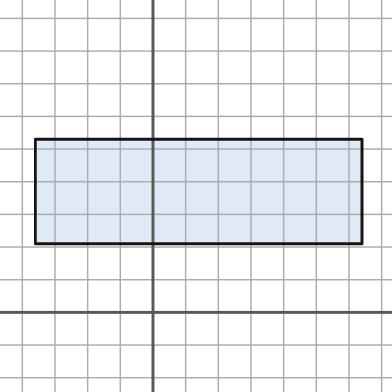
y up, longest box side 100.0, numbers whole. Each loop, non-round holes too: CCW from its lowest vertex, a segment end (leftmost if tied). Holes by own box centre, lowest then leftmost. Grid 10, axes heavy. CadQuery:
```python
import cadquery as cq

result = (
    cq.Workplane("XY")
    .moveTo(-36.0, 21.0)
    .lineTo(64.0, 21.0)
    .lineTo(64.0, 53.0)
    .lineTo(-36.0, 53.0)
    .close()
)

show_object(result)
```